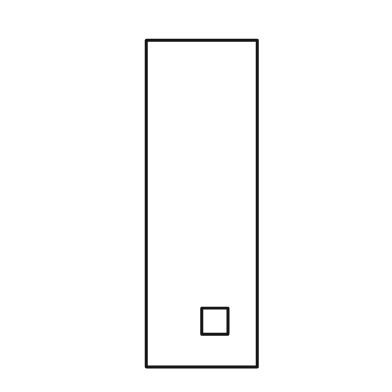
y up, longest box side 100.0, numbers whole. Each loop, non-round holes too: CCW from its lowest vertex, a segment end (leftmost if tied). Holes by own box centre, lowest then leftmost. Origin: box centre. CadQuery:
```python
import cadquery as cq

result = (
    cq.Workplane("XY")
    .moveTo(-17.0, -50.0)
    .lineTo(17.0, -50.0)
    .lineTo(17.0, 50.0)
    .lineTo(-17.0, 50.0)
    .close()
    .moveTo(0.0, -40.0)
    .lineTo(8.0, -40.0)
    .lineTo(8.0, -32.0)
    .lineTo(0.0, -32.0)
    .close()
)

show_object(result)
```